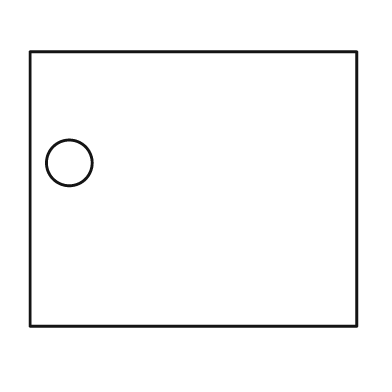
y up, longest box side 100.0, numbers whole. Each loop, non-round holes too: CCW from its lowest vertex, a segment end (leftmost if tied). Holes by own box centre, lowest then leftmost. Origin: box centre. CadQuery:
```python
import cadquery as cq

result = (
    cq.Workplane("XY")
    .moveTo(-50.0, -42.0)
    .lineTo(50.0, -42.0)
    .lineTo(50.0, 42.0)
    .lineTo(-50.0, 42.0)
    .close()
    .moveTo(-38.0, 8.0)
    .circle(7.0)
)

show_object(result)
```